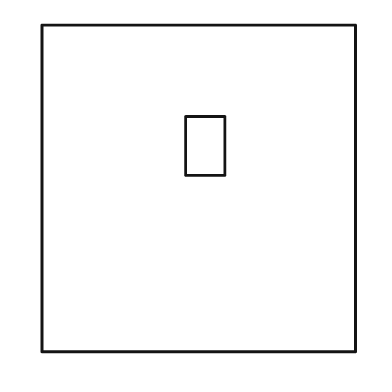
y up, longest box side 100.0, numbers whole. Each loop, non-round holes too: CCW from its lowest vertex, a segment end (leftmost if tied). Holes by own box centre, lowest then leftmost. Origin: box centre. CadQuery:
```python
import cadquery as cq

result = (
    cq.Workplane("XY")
    .moveTo(-48.0, -50.0)
    .lineTo(48.0, -50.0)
    .lineTo(48.0, 50.0)
    .lineTo(-48.0, 50.0)
    .close()
    .moveTo(-4.0, 4.0)
    .lineTo(8.0, 4.0)
    .lineTo(8.0, 22.0)
    .lineTo(-4.0, 22.0)
    .close()
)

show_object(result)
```